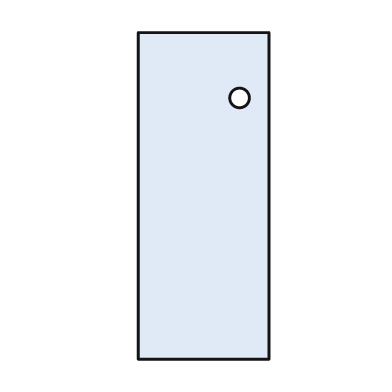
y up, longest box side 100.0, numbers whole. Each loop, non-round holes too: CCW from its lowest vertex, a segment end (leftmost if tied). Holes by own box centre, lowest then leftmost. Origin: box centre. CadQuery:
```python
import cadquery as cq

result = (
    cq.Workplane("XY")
    .moveTo(-20.0, -50.0)
    .lineTo(20.0, -50.0)
    .lineTo(20.0, 50.0)
    .lineTo(-20.0, 50.0)
    .close()
    .moveTo(11.0, 30.0)
    .circle(3.0)
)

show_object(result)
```